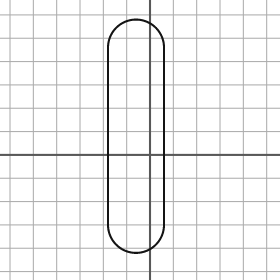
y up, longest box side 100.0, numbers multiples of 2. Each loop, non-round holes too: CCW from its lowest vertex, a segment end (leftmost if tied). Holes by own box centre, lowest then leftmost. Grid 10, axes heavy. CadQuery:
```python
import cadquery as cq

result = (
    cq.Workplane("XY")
    .moveTo(-18.0, -30.0)
    .threePointArc((-6.0, -42.0), (6.0, -30.0))
    .lineTo(6.0, 46.0)
    .threePointArc((-6.0, 58.0), (-18.0, 46.0))
    .close()
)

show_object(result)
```